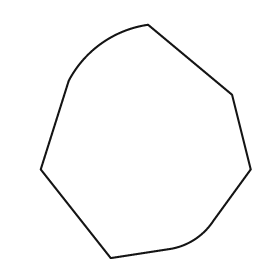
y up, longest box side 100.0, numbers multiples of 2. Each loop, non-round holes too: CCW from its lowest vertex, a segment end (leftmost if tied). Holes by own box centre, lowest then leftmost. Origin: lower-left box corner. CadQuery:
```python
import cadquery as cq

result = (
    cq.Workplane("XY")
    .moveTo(30.0, 0.0)
    .lineTo(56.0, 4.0)
    .threePointArc((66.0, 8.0), (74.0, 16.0))
    .lineTo(90.0, 38.0)
    .lineTo(82.0, 70.0)
    .lineTo(46.0, 100.0)
    .threePointArc((26.0, 92.0), (12.0, 76.0))
    .lineTo(0.0, 38.0)
    .close()
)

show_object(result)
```